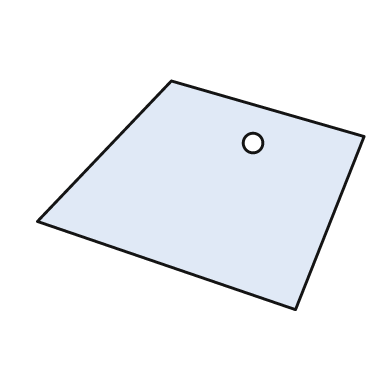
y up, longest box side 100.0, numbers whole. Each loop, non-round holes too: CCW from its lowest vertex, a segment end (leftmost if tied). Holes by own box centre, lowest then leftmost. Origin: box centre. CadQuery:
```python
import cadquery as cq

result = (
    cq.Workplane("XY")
    .moveTo(29.0, -35.0)
    .lineTo(50.0, 18.0)
    .lineTo(-9.0, 35.0)
    .lineTo(-50.0, -8.0)
    .close()
    .moveTo(16.0, 16.0)
    .circle(3.0)
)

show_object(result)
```